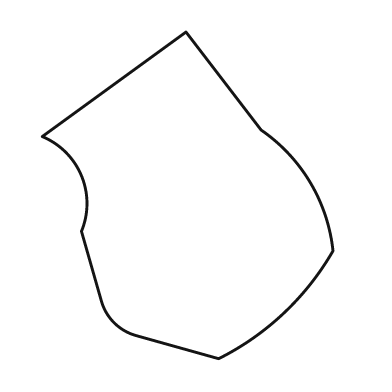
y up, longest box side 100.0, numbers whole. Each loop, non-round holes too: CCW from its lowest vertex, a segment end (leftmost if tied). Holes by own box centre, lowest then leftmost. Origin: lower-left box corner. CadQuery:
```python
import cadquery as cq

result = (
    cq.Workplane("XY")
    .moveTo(54.0, 0.0)
    .threePointArc((74.0, 14.0), (89.0, 33.0))
    .threePointArc((82.0, 54.0), (67.0, 70.0))
    .lineTo(44.0, 100.0)
    .lineTo(0.0, 68.0)
    .threePointArc((12.0, 56.0), (12.0, 39.0))
    .lineTo(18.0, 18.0)
    .threePointArc((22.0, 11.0), (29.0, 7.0))
    .close()
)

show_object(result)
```